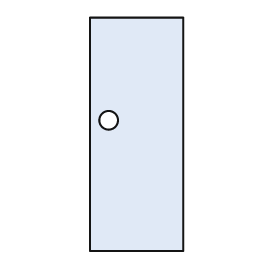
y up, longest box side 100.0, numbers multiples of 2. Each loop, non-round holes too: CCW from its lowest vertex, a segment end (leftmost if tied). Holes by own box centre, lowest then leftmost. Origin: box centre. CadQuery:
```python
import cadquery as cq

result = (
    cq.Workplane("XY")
    .moveTo(-20.0, -50.0)
    .lineTo(20.0, -50.0)
    .lineTo(20.0, 50.0)
    .lineTo(-20.0, 50.0)
    .close()
    .moveTo(-12.0, 6.0)
    .circle(4.0)
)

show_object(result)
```